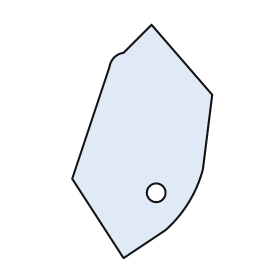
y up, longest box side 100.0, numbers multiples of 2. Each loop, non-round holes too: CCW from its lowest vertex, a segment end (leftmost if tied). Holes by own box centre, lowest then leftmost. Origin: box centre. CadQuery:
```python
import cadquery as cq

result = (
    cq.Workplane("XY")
    .moveTo(-8.0, -50.0)
    .lineTo(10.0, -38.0)
    .threePointArc((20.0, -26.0), (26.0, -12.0))
    .lineTo(30.0, 20.0)
    .lineTo(4.0, 50.0)
    .lineTo(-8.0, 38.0)
    .threePointArc((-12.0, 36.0), (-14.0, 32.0))
    .lineTo(-30.0, -16.0)
    .close()
    .moveTo(6.0, -22.0)
    .circle(4.0)
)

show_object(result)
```